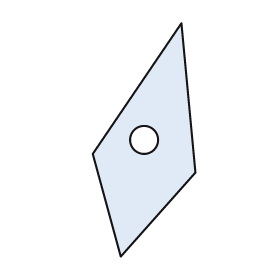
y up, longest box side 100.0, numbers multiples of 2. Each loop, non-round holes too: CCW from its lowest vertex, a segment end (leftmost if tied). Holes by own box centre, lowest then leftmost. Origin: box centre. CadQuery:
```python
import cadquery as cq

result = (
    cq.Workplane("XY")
    .moveTo(-10.0, -50.0)
    .lineTo(22.0, -14.0)
    .lineTo(16.0, 50.0)
    .lineTo(-22.0, -6.0)
    .close()
    .moveTo(0.0, 0.0)
    .circle(6.0)
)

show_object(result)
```